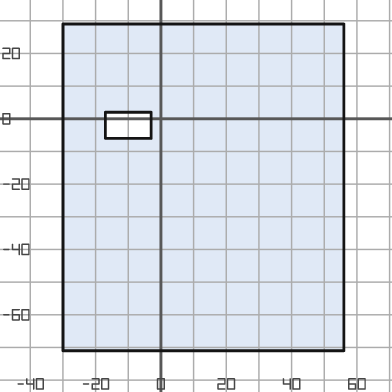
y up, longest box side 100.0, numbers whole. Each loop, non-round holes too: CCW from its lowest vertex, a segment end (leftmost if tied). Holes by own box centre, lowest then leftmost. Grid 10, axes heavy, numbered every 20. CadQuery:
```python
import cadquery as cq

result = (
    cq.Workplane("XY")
    .moveTo(-30.0, -71.0)
    .lineTo(56.0, -71.0)
    .lineTo(56.0, 29.0)
    .lineTo(-30.0, 29.0)
    .close()
    .moveTo(-17.0, -6.0)
    .lineTo(-3.0, -6.0)
    .lineTo(-3.0, 2.0)
    .lineTo(-17.0, 2.0)
    .close()
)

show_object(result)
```